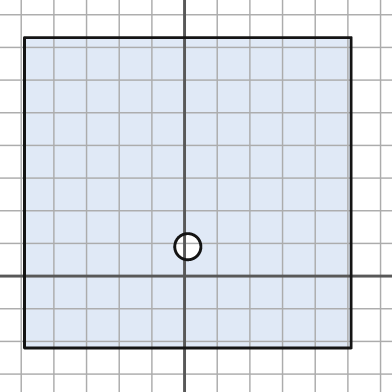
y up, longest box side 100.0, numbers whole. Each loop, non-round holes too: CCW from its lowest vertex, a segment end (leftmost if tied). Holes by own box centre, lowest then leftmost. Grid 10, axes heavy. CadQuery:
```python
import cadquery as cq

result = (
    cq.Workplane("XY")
    .moveTo(-49.0, -22.0)
    .lineTo(51.0, -22.0)
    .lineTo(51.0, 73.0)
    .lineTo(-49.0, 73.0)
    .close()
    .moveTo(1.0, 9.0)
    .circle(4.0)
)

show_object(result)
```